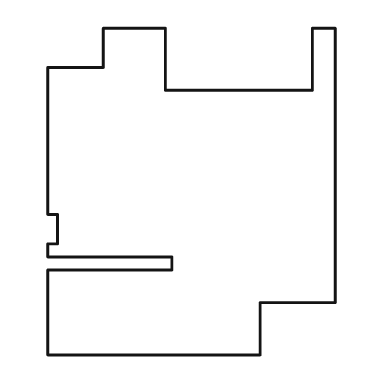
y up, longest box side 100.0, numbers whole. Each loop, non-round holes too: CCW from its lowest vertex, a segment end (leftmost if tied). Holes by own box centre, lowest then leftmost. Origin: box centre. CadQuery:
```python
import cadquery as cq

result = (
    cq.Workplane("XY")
    .moveTo(-44.0, -50.0)
    .lineTo(21.0, -50.0)
    .lineTo(21.0, -34.0)
    .lineTo(44.0, -34.0)
    .lineTo(44.0, 50.0)
    .lineTo(37.0, 50.0)
    .lineTo(37.0, 31.0)
    .lineTo(-8.0, 31.0)
    .lineTo(-8.0, 50.0)
    .lineTo(-27.0, 50.0)
    .lineTo(-27.0, 38.0)
    .lineTo(-44.0, 38.0)
    .lineTo(-44.0, -7.0)
    .lineTo(-41.0, -7.0)
    .lineTo(-41.0, -16.0)
    .lineTo(-44.0, -16.0)
    .lineTo(-44.0, -20.0)
    .lineTo(-6.0, -20.0)
    .lineTo(-6.0, -24.0)
    .lineTo(-44.0, -24.0)
    .close()
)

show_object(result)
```